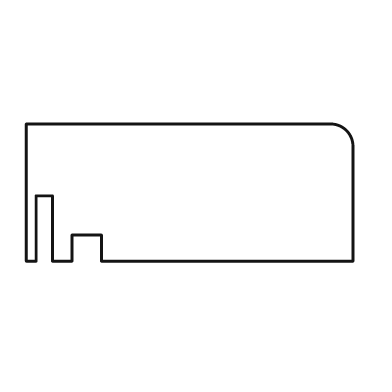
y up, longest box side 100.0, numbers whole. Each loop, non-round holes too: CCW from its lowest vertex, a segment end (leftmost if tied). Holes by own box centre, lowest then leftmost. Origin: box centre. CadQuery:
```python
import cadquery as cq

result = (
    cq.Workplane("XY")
    .moveTo(-50.0, -21.0)
    .lineTo(-47.0, -21.0)
    .lineTo(-47.0, -1.0)
    .lineTo(-42.0, -1.0)
    .lineTo(-42.0, -21.0)
    .lineTo(-36.0, -21.0)
    .lineTo(-36.0, -13.0)
    .lineTo(-27.0, -13.0)
    .lineTo(-27.0, -21.0)
    .lineTo(50.0, -21.0)
    .lineTo(50.0, 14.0)
    .threePointArc((48.0, 19.0), (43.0, 21.0))
    .lineTo(-50.0, 21.0)
    .close()
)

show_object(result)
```